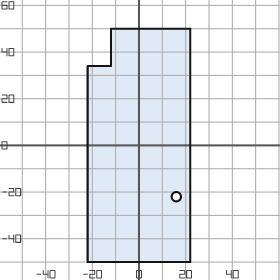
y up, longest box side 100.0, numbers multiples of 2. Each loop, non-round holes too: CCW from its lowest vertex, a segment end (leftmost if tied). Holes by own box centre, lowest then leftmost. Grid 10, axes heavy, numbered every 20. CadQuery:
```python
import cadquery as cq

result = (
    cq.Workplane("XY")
    .moveTo(-22.0, -50.0)
    .lineTo(22.0, -50.0)
    .lineTo(22.0, 50.0)
    .lineTo(-12.0, 50.0)
    .lineTo(-12.0, 34.0)
    .lineTo(-22.0, 34.0)
    .close()
    .moveTo(16.0, -22.0)
    .circle(2.0)
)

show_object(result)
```